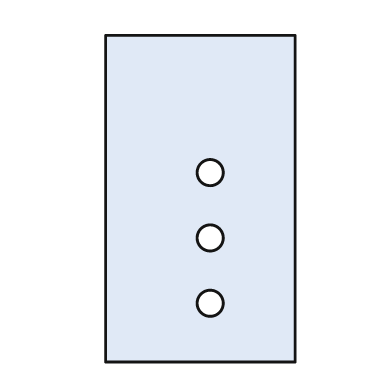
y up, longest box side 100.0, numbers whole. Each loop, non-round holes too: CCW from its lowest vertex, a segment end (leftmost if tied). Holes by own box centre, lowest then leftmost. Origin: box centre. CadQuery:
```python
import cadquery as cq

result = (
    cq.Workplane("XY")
    .moveTo(-29.0, -50.0)
    .lineTo(29.0, -50.0)
    .lineTo(29.0, 50.0)
    .lineTo(-29.0, 50.0)
    .close()
    .moveTo(3.0, -32.0)
    .circle(4.0)
    .moveTo(3.0, -12.0)
    .circle(4.0)
    .moveTo(3.0, 8.0)
    .circle(4.0)
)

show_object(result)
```